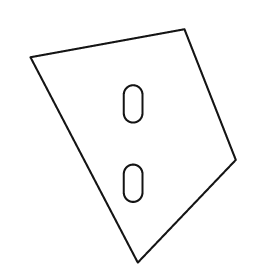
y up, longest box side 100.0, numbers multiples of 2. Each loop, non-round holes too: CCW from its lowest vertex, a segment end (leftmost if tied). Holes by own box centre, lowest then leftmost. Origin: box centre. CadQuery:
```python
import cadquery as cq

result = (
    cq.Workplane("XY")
    .moveTo(2.0, -50.0)
    .lineTo(44.0, -6.0)
    .lineTo(22.0, 50.0)
    .lineTo(-44.0, 38.0)
    .close()
    .moveTo(-4.0, -20.0)
    .threePointArc((0.0, -24.0), (4.0, -20.0))
    .lineTo(4.0, -12.0)
    .threePointArc((0.0, -8.0), (-4.0, -12.0))
    .close()
    .moveTo(-4.0, 14.0)
    .threePointArc((0.0, 10.0), (4.0, 14.0))
    .lineTo(4.0, 22.0)
    .threePointArc((0.0, 26.0), (-4.0, 22.0))
    .close()
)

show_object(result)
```